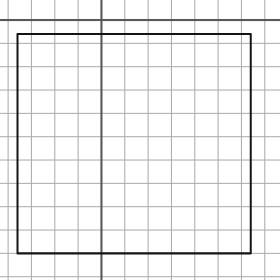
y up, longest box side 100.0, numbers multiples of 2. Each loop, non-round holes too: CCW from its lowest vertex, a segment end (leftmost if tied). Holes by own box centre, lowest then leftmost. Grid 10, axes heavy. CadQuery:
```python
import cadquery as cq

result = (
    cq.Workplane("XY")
    .moveTo(-36.0, -100.0)
    .lineTo(64.0, -100.0)
    .lineTo(64.0, -6.0)
    .lineTo(-36.0, -6.0)
    .close()
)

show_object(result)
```